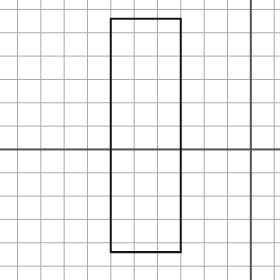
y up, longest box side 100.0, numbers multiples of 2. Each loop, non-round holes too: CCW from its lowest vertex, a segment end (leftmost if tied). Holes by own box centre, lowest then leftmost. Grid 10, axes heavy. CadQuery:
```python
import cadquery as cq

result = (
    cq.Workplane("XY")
    .moveTo(-60.0, -44.0)
    .lineTo(-30.0, -44.0)
    .lineTo(-30.0, 56.0)
    .lineTo(-60.0, 56.0)
    .close()
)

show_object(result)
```